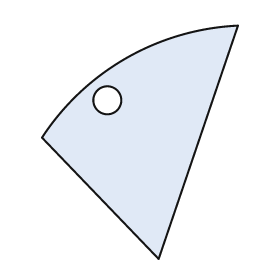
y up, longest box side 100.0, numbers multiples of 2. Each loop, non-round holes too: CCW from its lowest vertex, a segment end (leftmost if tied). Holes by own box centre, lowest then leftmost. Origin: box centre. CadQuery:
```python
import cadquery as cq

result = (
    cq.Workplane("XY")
    .moveTo(8.0, -50.0)
    .lineTo(42.0, 50.0)
    .threePointArc((-6.0, 36.0), (-42.0, 2.0))
    .close()
    .moveTo(-14.0, 18.0)
    .circle(6.0)
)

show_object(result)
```